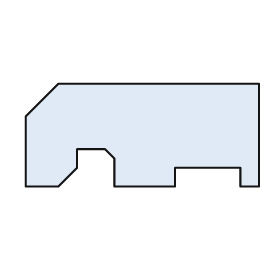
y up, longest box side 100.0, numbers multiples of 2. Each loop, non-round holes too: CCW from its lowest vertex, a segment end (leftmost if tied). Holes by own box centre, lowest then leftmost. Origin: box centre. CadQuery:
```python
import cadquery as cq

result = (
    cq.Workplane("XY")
    .moveTo(-50.0, -22.0)
    .lineTo(-36.0, -22.0)
    .lineTo(-28.0, -14.0)
    .lineTo(-28.0, -6.0)
    .lineTo(-16.0, -6.0)
    .lineTo(-12.0, -10.0)
    .lineTo(-12.0, -22.0)
    .lineTo(14.0, -22.0)
    .lineTo(14.0, -14.0)
    .lineTo(42.0, -14.0)
    .lineTo(42.0, -22.0)
    .lineTo(50.0, -22.0)
    .lineTo(50.0, 22.0)
    .lineTo(-36.0, 22.0)
    .lineTo(-50.0, 8.0)
    .close()
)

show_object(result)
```